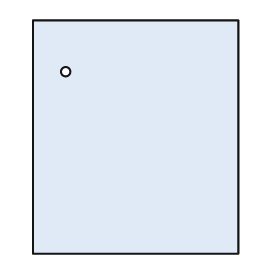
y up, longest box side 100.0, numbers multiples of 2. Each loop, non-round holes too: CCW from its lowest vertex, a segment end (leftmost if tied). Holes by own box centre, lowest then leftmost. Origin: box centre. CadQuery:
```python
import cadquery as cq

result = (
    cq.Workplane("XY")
    .moveTo(-44.0, -50.0)
    .lineTo(44.0, -50.0)
    .lineTo(44.0, 50.0)
    .lineTo(-44.0, 50.0)
    .close()
    .moveTo(-30.0, 28.0)
    .circle(2.0)
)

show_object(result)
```